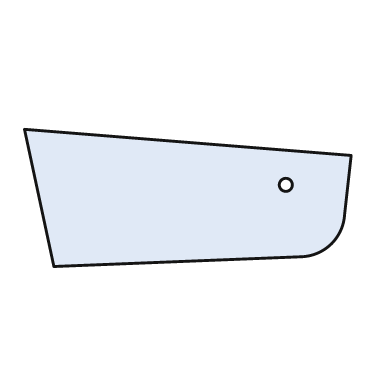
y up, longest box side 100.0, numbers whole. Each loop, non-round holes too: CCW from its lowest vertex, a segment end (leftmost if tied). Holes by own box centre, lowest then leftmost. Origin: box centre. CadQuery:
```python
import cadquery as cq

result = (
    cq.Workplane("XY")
    .moveTo(-41.0, -21.0)
    .lineTo(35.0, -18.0)
    .threePointArc((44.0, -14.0), (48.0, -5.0))
    .lineTo(50.0, 13.0)
    .lineTo(-50.0, 21.0)
    .close()
    .moveTo(30.0, 4.0)
    .circle(2.0)
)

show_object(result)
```